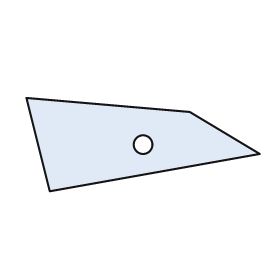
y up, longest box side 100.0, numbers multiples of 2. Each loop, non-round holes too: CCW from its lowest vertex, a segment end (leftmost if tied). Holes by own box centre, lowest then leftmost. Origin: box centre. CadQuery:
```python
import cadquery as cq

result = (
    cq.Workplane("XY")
    .moveTo(-40.0, -20.0)
    .lineTo(50.0, -4.0)
    .lineTo(20.0, 14.0)
    .lineTo(-50.0, 20.0)
    .close()
    .moveTo(0.0, 0.0)
    .circle(4.0)
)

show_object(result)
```